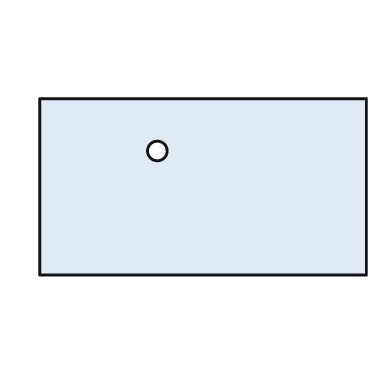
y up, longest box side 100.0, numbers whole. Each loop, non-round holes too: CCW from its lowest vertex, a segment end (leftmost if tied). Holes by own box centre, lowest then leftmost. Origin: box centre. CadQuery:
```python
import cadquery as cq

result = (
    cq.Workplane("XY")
    .moveTo(-50.0, -27.0)
    .lineTo(50.0, -27.0)
    .lineTo(50.0, 27.0)
    .lineTo(-50.0, 27.0)
    .close()
    .moveTo(-14.0, 11.0)
    .circle(3.0)
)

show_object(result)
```